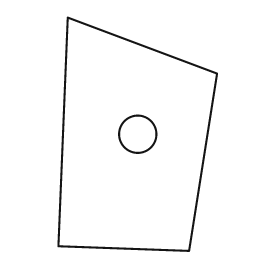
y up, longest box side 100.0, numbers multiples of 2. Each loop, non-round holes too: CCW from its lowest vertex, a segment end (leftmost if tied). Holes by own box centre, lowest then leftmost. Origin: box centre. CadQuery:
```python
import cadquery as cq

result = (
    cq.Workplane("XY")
    .moveTo(22.0, -50.0)
    .lineTo(34.0, 26.0)
    .lineTo(-30.0, 50.0)
    .lineTo(-34.0, -48.0)
    .close()
    .moveTo(0.0, 0.0)
    .circle(8.0)
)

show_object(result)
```